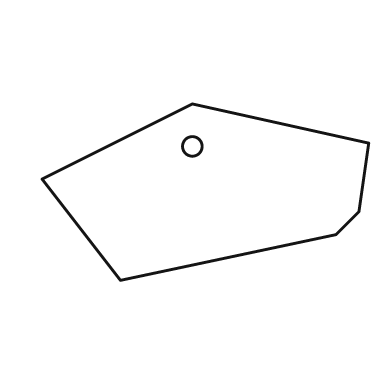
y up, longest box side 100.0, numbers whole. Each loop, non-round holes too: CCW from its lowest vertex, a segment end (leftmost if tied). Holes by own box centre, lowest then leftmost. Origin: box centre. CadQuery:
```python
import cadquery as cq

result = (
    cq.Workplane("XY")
    .moveTo(-26.0, -27.0)
    .lineTo(40.0, -13.0)
    .lineTo(47.0, -6.0)
    .lineTo(50.0, 15.0)
    .lineTo(-4.0, 27.0)
    .lineTo(-50.0, 4.0)
    .close()
    .moveTo(-4.0, 14.0)
    .circle(3.0)
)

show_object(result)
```